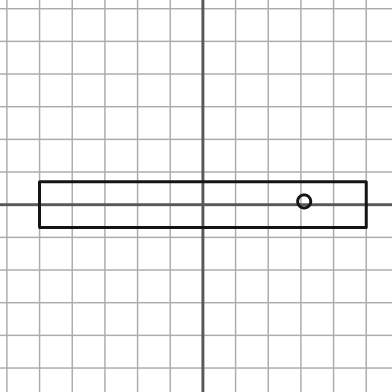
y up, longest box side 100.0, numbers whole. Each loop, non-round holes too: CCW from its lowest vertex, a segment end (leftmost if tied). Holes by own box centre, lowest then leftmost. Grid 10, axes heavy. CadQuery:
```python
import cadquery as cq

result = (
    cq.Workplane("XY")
    .moveTo(-50.0, -7.0)
    .lineTo(50.0, -7.0)
    .lineTo(50.0, 7.0)
    .lineTo(-50.0, 7.0)
    .close()
    .moveTo(31.0, 1.0)
    .circle(2.0)
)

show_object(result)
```